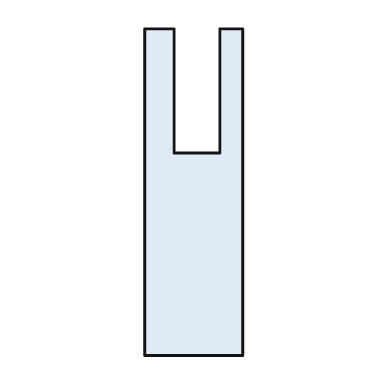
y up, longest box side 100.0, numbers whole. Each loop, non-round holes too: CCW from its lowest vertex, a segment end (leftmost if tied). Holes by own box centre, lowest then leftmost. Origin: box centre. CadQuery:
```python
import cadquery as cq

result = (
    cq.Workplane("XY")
    .moveTo(-15.0, -50.0)
    .lineTo(15.0, -50.0)
    .lineTo(15.0, 50.0)
    .lineTo(8.0, 50.0)
    .lineTo(8.0, 12.0)
    .lineTo(-6.0, 12.0)
    .lineTo(-6.0, 50.0)
    .lineTo(-15.0, 50.0)
    .close()
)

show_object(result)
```